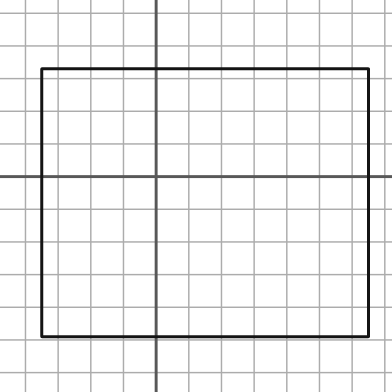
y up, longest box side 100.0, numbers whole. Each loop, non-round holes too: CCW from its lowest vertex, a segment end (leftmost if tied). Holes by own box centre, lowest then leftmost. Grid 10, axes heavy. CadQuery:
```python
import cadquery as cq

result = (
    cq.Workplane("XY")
    .moveTo(-35.0, -49.0)
    .lineTo(65.0, -49.0)
    .lineTo(65.0, 33.0)
    .lineTo(-35.0, 33.0)
    .close()
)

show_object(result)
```